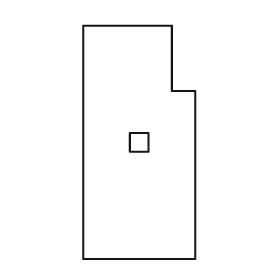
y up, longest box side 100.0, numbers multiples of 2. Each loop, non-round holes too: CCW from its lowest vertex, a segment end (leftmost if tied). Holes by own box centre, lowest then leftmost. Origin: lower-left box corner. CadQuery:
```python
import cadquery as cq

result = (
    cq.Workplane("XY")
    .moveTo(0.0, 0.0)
    .lineTo(48.0, 0.0)
    .lineTo(48.0, 72.0)
    .lineTo(38.0, 72.0)
    .lineTo(38.0, 100.0)
    .lineTo(0.0, 100.0)
    .close()
    .moveTo(20.0, 46.0)
    .lineTo(28.0, 46.0)
    .lineTo(28.0, 54.0)
    .lineTo(20.0, 54.0)
    .close()
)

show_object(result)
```